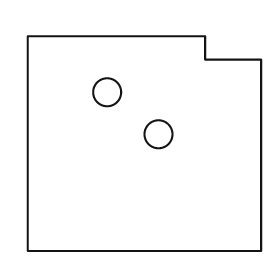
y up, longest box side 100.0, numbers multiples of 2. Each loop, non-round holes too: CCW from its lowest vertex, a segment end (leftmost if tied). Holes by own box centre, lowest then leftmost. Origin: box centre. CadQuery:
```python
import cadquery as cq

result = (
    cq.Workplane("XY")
    .moveTo(-50.0, -46.0)
    .lineTo(50.0, -46.0)
    .lineTo(50.0, 36.0)
    .lineTo(26.0, 36.0)
    .lineTo(26.0, 46.0)
    .lineTo(-50.0, 46.0)
    .close()
    .moveTo(6.0, 4.0)
    .circle(6.0)
    .moveTo(-16.0, 22.0)
    .circle(6.0)
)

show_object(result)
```